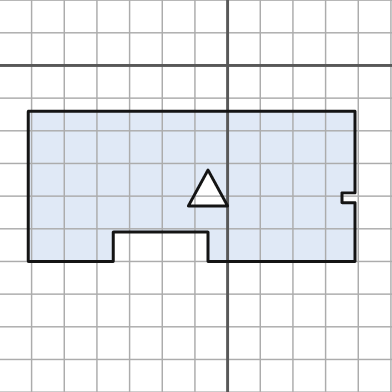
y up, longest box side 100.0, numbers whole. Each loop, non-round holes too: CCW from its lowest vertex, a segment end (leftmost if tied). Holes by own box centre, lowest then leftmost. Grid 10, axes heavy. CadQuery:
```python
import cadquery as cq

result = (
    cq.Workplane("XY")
    .moveTo(-61.0, -60.0)
    .lineTo(-35.0, -60.0)
    .lineTo(-35.0, -51.0)
    .lineTo(-6.0, -51.0)
    .lineTo(-6.0, -60.0)
    .lineTo(39.0, -60.0)
    .lineTo(39.0, -42.0)
    .lineTo(35.0, -42.0)
    .lineTo(35.0, -39.0)
    .lineTo(39.0, -39.0)
    .lineTo(39.0, -14.0)
    .lineTo(-61.0, -14.0)
    .close()
    .moveTo(-12.0, -43.0)
    .lineTo(0.0, -43.0)
    .lineTo(-6.0, -32.0)
    .close()
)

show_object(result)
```